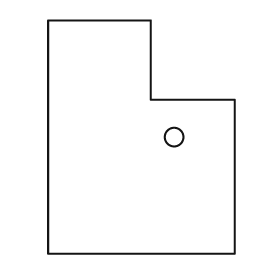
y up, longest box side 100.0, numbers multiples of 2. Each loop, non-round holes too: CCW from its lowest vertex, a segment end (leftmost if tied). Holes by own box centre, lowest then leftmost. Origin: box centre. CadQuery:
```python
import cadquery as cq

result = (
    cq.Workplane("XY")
    .moveTo(-40.0, -50.0)
    .lineTo(40.0, -50.0)
    .lineTo(40.0, 16.0)
    .lineTo(4.0, 16.0)
    .lineTo(4.0, 50.0)
    .lineTo(-40.0, 50.0)
    .close()
    .moveTo(14.0, 0.0)
    .circle(4.0)
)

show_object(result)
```